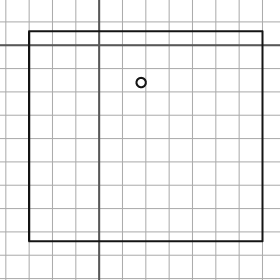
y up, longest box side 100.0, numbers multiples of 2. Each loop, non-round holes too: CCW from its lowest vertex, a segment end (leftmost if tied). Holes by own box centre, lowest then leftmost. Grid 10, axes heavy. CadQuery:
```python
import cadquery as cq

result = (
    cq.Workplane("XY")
    .moveTo(-30.0, -84.0)
    .lineTo(70.0, -84.0)
    .lineTo(70.0, 6.0)
    .lineTo(-30.0, 6.0)
    .close()
    .moveTo(18.0, -16.0)
    .circle(2.0)
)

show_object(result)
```